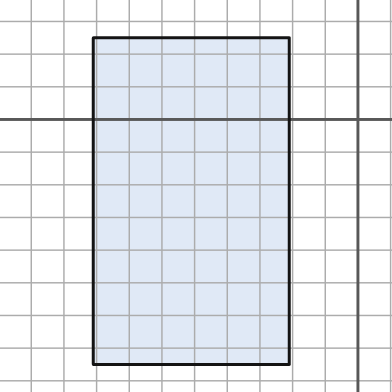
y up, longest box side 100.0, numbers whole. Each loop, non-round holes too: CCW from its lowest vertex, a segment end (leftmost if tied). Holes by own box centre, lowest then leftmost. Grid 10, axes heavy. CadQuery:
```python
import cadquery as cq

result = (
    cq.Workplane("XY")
    .moveTo(-81.0, -75.0)
    .lineTo(-21.0, -75.0)
    .lineTo(-21.0, 25.0)
    .lineTo(-81.0, 25.0)
    .close()
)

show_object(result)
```